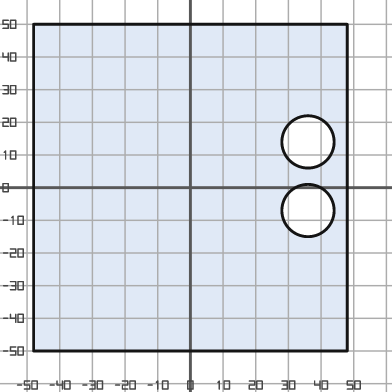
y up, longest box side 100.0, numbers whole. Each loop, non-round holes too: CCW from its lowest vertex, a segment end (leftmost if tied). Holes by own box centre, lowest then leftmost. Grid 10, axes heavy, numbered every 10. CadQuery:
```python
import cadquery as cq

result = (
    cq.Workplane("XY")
    .moveTo(-48.0, -50.0)
    .lineTo(48.0, -50.0)
    .lineTo(48.0, 50.0)
    .lineTo(-48.0, 50.0)
    .close()
    .moveTo(36.0, -7.0)
    .circle(8.0)
    .moveTo(36.0, 14.0)
    .circle(8.0)
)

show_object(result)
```